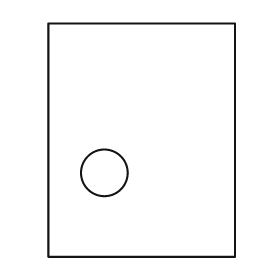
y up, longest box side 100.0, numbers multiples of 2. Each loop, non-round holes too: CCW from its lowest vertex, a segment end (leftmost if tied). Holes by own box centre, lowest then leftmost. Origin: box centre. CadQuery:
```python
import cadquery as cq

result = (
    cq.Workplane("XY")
    .moveTo(-40.0, -50.0)
    .lineTo(40.0, -50.0)
    .lineTo(40.0, 50.0)
    .lineTo(-40.0, 50.0)
    .close()
    .moveTo(-16.0, -14.0)
    .circle(10.0)
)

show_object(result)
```